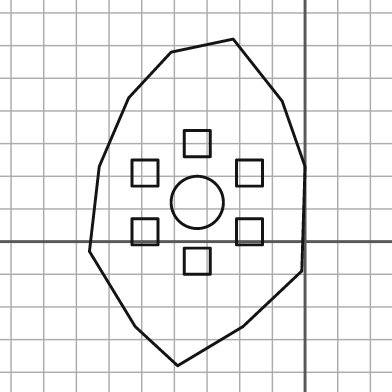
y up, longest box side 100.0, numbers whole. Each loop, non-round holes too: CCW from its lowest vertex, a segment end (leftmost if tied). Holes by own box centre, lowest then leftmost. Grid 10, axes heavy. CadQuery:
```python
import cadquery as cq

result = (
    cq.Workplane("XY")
    .moveTo(-39.0, -38.0)
    .lineTo(-19.0, -26.0)
    .lineTo(-1.0, -9.0)
    .lineTo(0.0, 23.0)
    .lineTo(-7.0, 43.0)
    .lineTo(-22.0, 62.0)
    .lineTo(-41.0, 58.0)
    .lineTo(-54.0, 44.0)
    .lineTo(-63.0, 23.0)
    .lineTo(-66.0, -3.0)
    .lineTo(-52.0, -26.0)
    .close()
    .moveTo(-37.0, -10.0)
    .lineTo(-29.0, -10.0)
    .lineTo(-29.0, -2.0)
    .lineTo(-37.0, -2.0)
    .close()
    .moveTo(-53.0, -1.0)
    .lineTo(-45.0, -1.0)
    .lineTo(-45.0, 7.0)
    .lineTo(-53.0, 7.0)
    .close()
    .moveTo(-21.0, -1.0)
    .lineTo(-13.0, -1.0)
    .lineTo(-13.0, 7.0)
    .lineTo(-21.0, 7.0)
    .close()
    .moveTo(-33.0, 12.0)
    .circle(8.0)
    .moveTo(-53.0, 17.0)
    .lineTo(-45.0, 17.0)
    .lineTo(-45.0, 25.0)
    .lineTo(-53.0, 25.0)
    .close()
    .moveTo(-21.0, 17.0)
    .lineTo(-13.0, 17.0)
    .lineTo(-13.0, 25.0)
    .lineTo(-21.0, 25.0)
    .close()
    .moveTo(-37.0, 26.0)
    .lineTo(-29.0, 26.0)
    .lineTo(-29.0, 34.0)
    .lineTo(-37.0, 34.0)
    .close()
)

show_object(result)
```